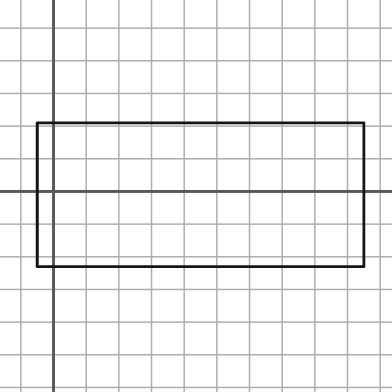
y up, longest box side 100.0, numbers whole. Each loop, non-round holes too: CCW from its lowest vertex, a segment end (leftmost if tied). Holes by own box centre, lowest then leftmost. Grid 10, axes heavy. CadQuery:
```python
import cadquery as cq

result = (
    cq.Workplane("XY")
    .moveTo(-5.0, -23.0)
    .lineTo(95.0, -23.0)
    .lineTo(95.0, 21.0)
    .lineTo(-5.0, 21.0)
    .close()
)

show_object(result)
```